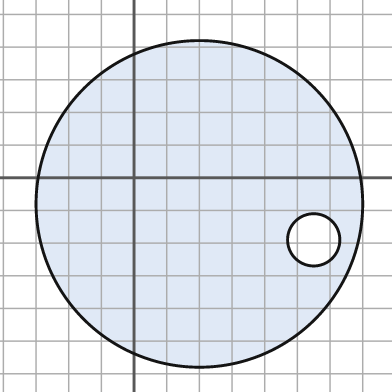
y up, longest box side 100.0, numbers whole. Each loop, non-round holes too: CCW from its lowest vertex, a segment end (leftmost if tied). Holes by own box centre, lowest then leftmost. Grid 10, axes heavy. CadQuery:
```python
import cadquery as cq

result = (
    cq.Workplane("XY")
    .moveTo(20.0, -8.0)
    .circle(50.0)
    .moveTo(55.0, -19.0)
    .circle(8.0)
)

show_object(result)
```